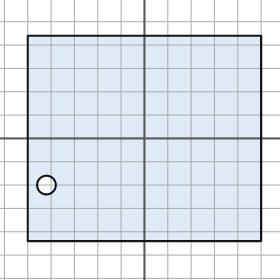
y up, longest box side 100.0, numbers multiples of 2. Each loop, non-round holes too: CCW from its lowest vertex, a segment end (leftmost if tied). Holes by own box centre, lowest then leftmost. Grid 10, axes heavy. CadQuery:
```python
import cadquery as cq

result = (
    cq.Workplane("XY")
    .moveTo(-50.0, -44.0)
    .lineTo(50.0, -44.0)
    .lineTo(50.0, 44.0)
    .lineTo(-50.0, 44.0)
    .close()
    .moveTo(-42.0, -20.0)
    .circle(4.0)
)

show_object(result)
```